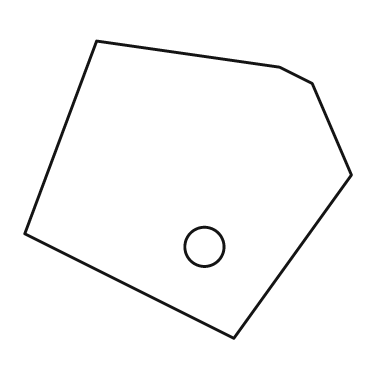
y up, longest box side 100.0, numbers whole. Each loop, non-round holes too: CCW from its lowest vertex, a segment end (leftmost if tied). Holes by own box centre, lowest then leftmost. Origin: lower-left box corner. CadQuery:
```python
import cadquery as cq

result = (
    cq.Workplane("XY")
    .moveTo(64.0, 0.0)
    .lineTo(100.0, 50.0)
    .lineTo(88.0, 78.0)
    .lineTo(78.0, 83.0)
    .lineTo(22.0, 91.0)
    .lineTo(0.0, 32.0)
    .close()
    .moveTo(55.0, 28.0)
    .circle(6.0)
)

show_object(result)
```